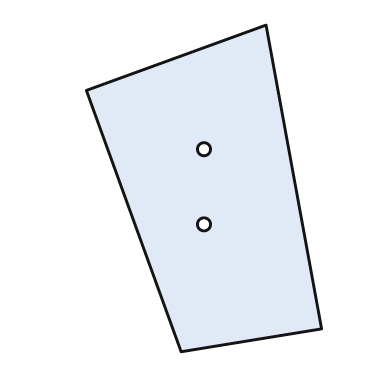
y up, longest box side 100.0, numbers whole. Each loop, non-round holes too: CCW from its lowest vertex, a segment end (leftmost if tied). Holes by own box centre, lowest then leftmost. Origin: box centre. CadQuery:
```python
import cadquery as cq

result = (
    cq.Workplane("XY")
    .moveTo(-7.0, -50.0)
    .lineTo(36.0, -43.0)
    .lineTo(19.0, 50.0)
    .lineTo(-36.0, 30.0)
    .close()
    .moveTo(0.0, -11.0)
    .circle(2.0)
    .moveTo(0.0, 12.0)
    .circle(2.0)
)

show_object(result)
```